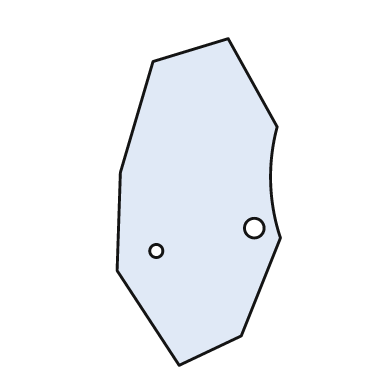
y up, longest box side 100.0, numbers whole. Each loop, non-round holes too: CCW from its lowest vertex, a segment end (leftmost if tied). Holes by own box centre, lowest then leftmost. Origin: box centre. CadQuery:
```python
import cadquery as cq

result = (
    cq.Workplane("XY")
    .moveTo(-6.0, -50.0)
    .lineTo(13.0, -41.0)
    .lineTo(25.0, -11.0)
    .threePointArc((22.0, 6.0), (24.0, 23.0))
    .lineTo(9.0, 50.0)
    .lineTo(-14.0, 43.0)
    .lineTo(-24.0, 9.0)
    .lineTo(-25.0, -21.0)
    .close()
    .moveTo(-13.0, -15.0)
    .circle(2.0)
    .moveTo(17.0, -8.0)
    .circle(3.0)
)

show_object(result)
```